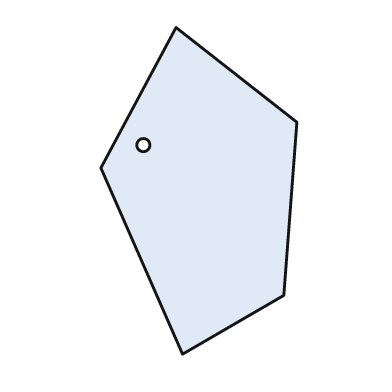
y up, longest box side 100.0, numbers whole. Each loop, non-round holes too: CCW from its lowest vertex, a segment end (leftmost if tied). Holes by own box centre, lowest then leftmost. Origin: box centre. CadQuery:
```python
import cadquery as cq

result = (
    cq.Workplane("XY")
    .moveTo(-5.0, -50.0)
    .lineTo(26.0, -32.0)
    .lineTo(30.0, 21.0)
    .lineTo(-7.0, 50.0)
    .lineTo(-30.0, 7.0)
    .close()
    .moveTo(-17.0, 14.0)
    .circle(2.0)
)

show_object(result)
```